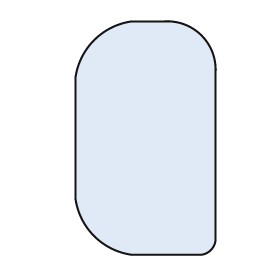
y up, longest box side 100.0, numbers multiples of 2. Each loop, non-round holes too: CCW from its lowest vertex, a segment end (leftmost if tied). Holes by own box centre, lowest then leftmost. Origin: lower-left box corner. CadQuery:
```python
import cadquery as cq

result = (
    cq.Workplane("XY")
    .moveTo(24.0, 0.0)
    .lineTo(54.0, 0.0)
    .threePointArc((58.0, 2.0), (60.0, 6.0))
    .lineTo(60.0, 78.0)
    .threePointArc((54.0, 94.0), (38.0, 100.0))
    .lineTo(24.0, 100.0)
    .threePointArc((8.0, 92.0), (0.0, 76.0))
    .lineTo(0.0, 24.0)
    .threePointArc((8.0, 8.0), (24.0, 0.0))
    .close()
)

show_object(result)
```